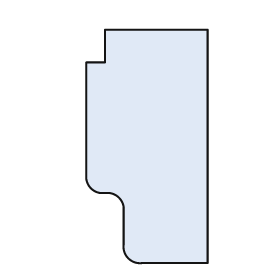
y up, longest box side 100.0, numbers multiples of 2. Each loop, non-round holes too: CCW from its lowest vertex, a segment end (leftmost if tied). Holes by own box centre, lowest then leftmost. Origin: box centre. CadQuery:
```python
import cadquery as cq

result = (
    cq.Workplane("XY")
    .moveTo(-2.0, -50.0)
    .lineTo(26.0, -50.0)
    .lineTo(26.0, 50.0)
    .lineTo(-18.0, 50.0)
    .lineTo(-18.0, 36.0)
    .lineTo(-26.0, 36.0)
    .lineTo(-26.0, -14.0)
    .threePointArc((-24.0, -18.0), (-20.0, -20.0))
    .lineTo(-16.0, -20.0)
    .threePointArc((-12.0, -22.0), (-10.0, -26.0))
    .lineTo(-10.0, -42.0)
    .threePointArc((-8.0, -48.0), (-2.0, -50.0))
    .close()
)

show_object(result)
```